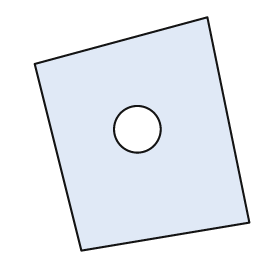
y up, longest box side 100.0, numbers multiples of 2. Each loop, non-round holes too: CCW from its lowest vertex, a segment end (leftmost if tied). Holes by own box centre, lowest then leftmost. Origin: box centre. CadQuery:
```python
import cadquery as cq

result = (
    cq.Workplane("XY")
    .moveTo(-26.0, -50.0)
    .lineTo(46.0, -38.0)
    .lineTo(28.0, 50.0)
    .lineTo(-46.0, 30.0)
    .close()
    .moveTo(-2.0, 2.0)
    .circle(10.0)
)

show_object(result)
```